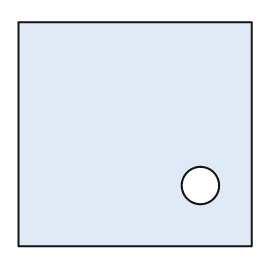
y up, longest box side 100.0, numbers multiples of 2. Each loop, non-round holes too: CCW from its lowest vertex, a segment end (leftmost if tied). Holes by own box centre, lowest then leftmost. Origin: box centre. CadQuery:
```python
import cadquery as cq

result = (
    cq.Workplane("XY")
    .moveTo(-50.0, -48.0)
    .lineTo(50.0, -48.0)
    .lineTo(50.0, 48.0)
    .lineTo(-50.0, 48.0)
    .close()
    .moveTo(28.0, -22.0)
    .circle(8.0)
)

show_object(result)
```